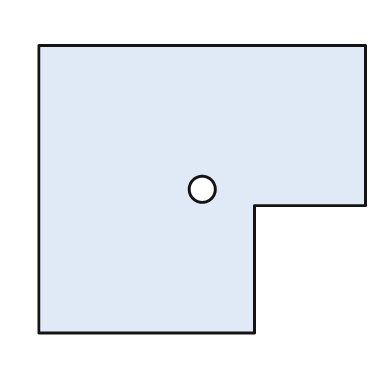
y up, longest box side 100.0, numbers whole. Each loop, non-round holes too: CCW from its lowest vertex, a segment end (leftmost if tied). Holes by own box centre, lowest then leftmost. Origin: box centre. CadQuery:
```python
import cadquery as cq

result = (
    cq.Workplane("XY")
    .moveTo(-50.0, -44.0)
    .lineTo(16.0, -44.0)
    .lineTo(16.0, -5.0)
    .lineTo(50.0, -5.0)
    .lineTo(50.0, 44.0)
    .lineTo(-50.0, 44.0)
    .close()
    .moveTo(0.0, 0.0)
    .circle(4.0)
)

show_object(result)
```